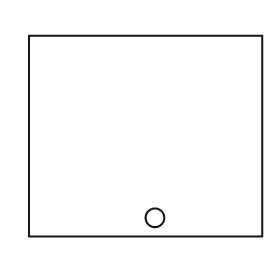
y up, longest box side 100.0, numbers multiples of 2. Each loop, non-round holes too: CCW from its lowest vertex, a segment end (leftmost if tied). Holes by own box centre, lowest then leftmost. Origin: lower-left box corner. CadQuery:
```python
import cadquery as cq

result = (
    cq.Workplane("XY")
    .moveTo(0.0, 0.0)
    .lineTo(100.0, 0.0)
    .lineTo(100.0, 86.0)
    .lineTo(0.0, 86.0)
    .close()
    .moveTo(54.0, 8.0)
    .circle(4.0)
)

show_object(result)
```